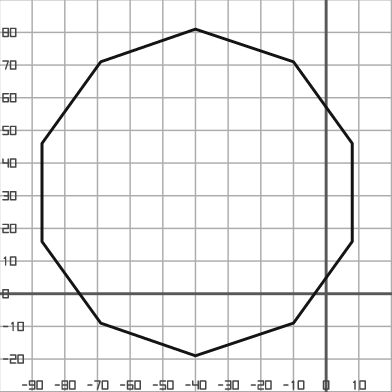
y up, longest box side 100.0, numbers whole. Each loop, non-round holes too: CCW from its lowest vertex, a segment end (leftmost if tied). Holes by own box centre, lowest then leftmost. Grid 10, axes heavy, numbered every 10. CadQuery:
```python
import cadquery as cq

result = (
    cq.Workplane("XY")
    .moveTo(-40.0, -19.0)
    .lineTo(-10.0, -9.0)
    .lineTo(8.0, 16.0)
    .lineTo(8.0, 46.0)
    .lineTo(-10.0, 71.0)
    .lineTo(-40.0, 81.0)
    .lineTo(-69.0, 71.0)
    .lineTo(-87.0, 46.0)
    .lineTo(-87.0, 16.0)
    .lineTo(-69.0, -9.0)
    .close()
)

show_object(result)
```